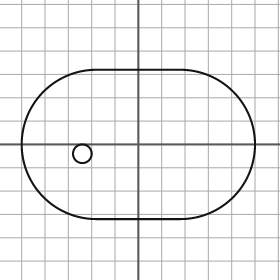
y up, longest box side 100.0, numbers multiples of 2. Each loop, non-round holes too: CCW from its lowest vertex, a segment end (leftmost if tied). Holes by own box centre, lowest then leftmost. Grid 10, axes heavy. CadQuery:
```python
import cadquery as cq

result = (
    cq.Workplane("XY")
    .moveTo(-18.0, -32.0)
    .lineTo(18.0, -32.0)
    .threePointArc((50.0, 0.0), (18.0, 32.0))
    .lineTo(-18.0, 32.0)
    .threePointArc((-50.0, 0.0), (-18.0, -32.0))
    .close()
    .moveTo(-24.0, -4.0)
    .circle(4.0)
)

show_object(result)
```